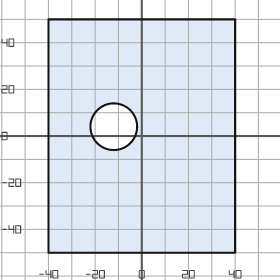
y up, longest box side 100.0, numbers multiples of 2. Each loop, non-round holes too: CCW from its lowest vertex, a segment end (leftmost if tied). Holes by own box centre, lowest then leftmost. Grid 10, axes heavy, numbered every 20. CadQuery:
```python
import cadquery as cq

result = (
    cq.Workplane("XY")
    .moveTo(-40.0, -50.0)
    .lineTo(40.0, -50.0)
    .lineTo(40.0, 50.0)
    .lineTo(-40.0, 50.0)
    .close()
    .moveTo(-12.0, 4.0)
    .circle(10.0)
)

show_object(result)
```